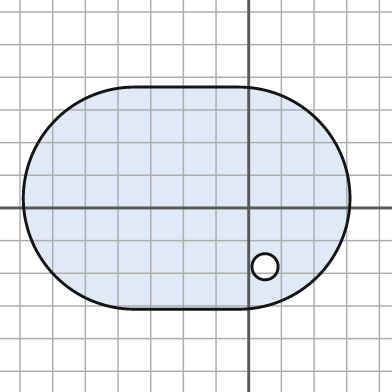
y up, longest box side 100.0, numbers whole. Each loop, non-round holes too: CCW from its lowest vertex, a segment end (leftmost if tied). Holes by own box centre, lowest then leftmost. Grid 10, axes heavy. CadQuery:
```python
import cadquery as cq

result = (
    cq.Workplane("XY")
    .moveTo(-35.0, -31.0)
    .lineTo(-3.0, -31.0)
    .threePointArc((31.0, 3.0), (-3.0, 37.0))
    .lineTo(-35.0, 37.0)
    .threePointArc((-69.0, 3.0), (-35.0, -31.0))
    .close()
    .moveTo(5.0, -18.0)
    .circle(4.0)
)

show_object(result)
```